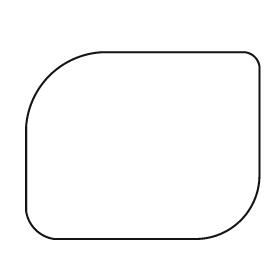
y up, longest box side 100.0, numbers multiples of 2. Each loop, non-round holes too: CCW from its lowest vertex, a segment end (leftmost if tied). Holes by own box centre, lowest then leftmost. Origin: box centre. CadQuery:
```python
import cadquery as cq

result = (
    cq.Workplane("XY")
    .moveTo(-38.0, -40.0)
    .lineTo(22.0, -40.0)
    .threePointArc((42.0, -32.0), (50.0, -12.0))
    .lineTo(50.0, 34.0)
    .threePointArc((48.0, 38.0), (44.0, 40.0))
    .lineTo(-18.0, 40.0)
    .threePointArc((-40.0, 30.0), (-50.0, 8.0))
    .lineTo(-50.0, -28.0)
    .threePointArc((-46.0, -36.0), (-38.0, -40.0))
    .close()
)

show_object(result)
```